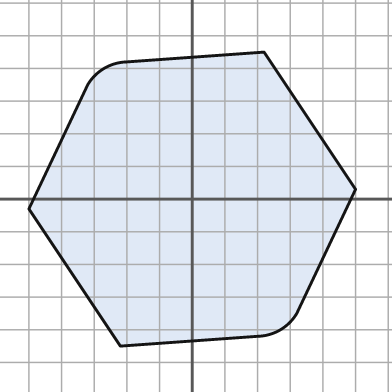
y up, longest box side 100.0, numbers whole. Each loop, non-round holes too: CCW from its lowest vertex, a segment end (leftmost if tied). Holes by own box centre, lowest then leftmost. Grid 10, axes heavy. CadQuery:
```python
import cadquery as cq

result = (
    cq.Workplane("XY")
    .moveTo(-22.0, -45.0)
    .lineTo(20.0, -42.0)
    .threePointArc((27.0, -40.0), (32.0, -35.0))
    .lineTo(50.0, 3.0)
    .lineTo(22.0, 45.0)
    .lineTo(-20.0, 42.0)
    .threePointArc((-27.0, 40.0), (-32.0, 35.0))
    .lineTo(-50.0, -3.0)
    .close()
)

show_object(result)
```